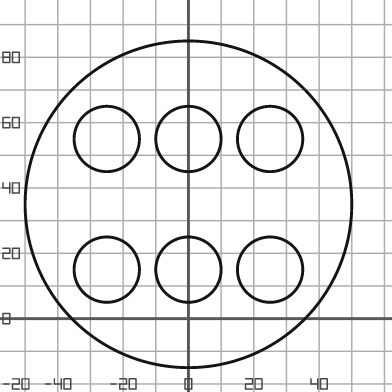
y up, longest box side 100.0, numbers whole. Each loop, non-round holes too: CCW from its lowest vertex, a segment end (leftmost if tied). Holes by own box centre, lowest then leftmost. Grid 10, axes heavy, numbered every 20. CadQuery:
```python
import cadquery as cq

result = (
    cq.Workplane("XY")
    .moveTo(0.0, 35.0)
    .circle(50.0)
    .moveTo(-25.0, 15.0)
    .circle(10.0)
    .moveTo(0.0, 15.0)
    .circle(10.0)
    .moveTo(25.0, 15.0)
    .circle(10.0)
    .moveTo(-25.0, 55.0)
    .circle(10.0)
    .moveTo(0.0, 55.0)
    .circle(10.0)
    .moveTo(25.0, 55.0)
    .circle(10.0)
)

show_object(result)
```